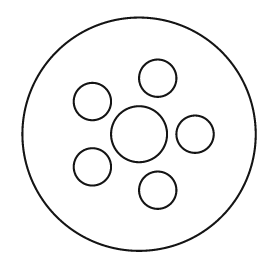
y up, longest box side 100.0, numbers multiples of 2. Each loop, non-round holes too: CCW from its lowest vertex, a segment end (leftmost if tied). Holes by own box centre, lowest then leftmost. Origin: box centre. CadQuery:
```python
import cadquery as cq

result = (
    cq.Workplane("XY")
    .moveTo(0.0, 0.0)
    .circle(50.0)
    .moveTo(8.0, -24.0)
    .circle(8.0)
    .moveTo(-20.0, -14.0)
    .circle(8.0)
    .moveTo(0.0, 0.0)
    .circle(12.0)
    .moveTo(24.0, 0.0)
    .circle(8.0)
    .moveTo(-20.0, 14.0)
    .circle(8.0)
    .moveTo(8.0, 24.0)
    .circle(8.0)
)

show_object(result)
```